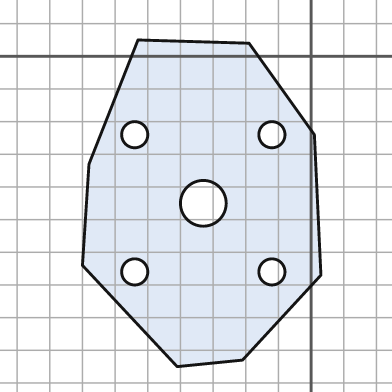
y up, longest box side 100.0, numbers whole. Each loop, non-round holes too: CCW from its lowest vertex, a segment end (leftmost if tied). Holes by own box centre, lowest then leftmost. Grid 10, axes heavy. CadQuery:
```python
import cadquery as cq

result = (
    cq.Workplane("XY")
    .moveTo(-41.0, -95.0)
    .lineTo(-21.0, -93.0)
    .lineTo(3.0, -67.0)
    .lineTo(1.0, -24.0)
    .lineTo(-19.0, 4.0)
    .lineTo(-53.0, 5.0)
    .lineTo(-68.0, -33.0)
    .lineTo(-70.0, -64.0)
    .close()
    .moveTo(-54.0, -66.0)
    .circle(4.0)
    .moveTo(-12.0, -66.0)
    .circle(4.0)
    .moveTo(-33.0, -45.0)
    .circle(7.0)
    .moveTo(-54.0, -24.0)
    .circle(4.0)
    .moveTo(-12.0, -24.0)
    .circle(4.0)
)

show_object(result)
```